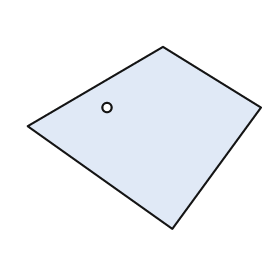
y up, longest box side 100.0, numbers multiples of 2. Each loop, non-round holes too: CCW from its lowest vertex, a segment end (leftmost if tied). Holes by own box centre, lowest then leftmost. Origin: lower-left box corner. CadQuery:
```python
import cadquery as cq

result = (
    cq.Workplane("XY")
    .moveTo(62.0, 0.0)
    .lineTo(100.0, 52.0)
    .lineTo(58.0, 78.0)
    .lineTo(0.0, 44.0)
    .close()
    .moveTo(34.0, 52.0)
    .circle(2.0)
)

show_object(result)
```